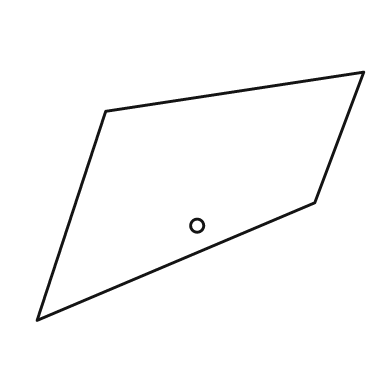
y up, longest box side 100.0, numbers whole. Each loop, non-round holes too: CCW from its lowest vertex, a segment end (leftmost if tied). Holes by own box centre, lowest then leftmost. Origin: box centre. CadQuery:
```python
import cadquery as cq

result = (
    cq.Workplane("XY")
    .moveTo(-50.0, -38.0)
    .lineTo(35.0, -2.0)
    .lineTo(50.0, 38.0)
    .lineTo(-29.0, 26.0)
    .close()
    .moveTo(-1.0, -9.0)
    .circle(2.0)
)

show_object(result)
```